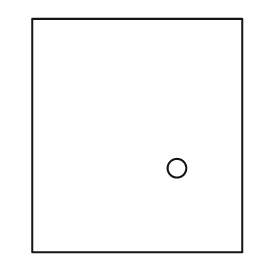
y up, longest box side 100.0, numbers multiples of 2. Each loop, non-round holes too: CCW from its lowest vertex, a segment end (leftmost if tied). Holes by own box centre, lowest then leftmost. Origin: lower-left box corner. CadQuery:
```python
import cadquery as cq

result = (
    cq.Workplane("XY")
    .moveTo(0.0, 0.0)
    .lineTo(90.0, 0.0)
    .lineTo(90.0, 100.0)
    .lineTo(0.0, 100.0)
    .close()
    .moveTo(62.0, 36.0)
    .circle(4.0)
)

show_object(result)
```